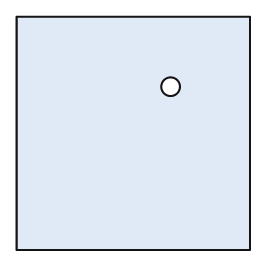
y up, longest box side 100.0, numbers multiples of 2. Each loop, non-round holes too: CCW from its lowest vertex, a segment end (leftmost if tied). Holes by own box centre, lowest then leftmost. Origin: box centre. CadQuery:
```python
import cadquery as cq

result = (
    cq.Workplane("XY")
    .moveTo(-50.0, -50.0)
    .lineTo(50.0, -50.0)
    .lineTo(50.0, 50.0)
    .lineTo(-50.0, 50.0)
    .close()
    .moveTo(16.0, 20.0)
    .circle(4.0)
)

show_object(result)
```